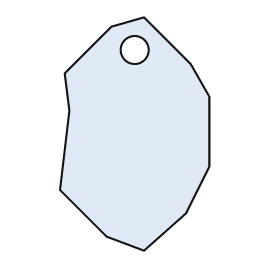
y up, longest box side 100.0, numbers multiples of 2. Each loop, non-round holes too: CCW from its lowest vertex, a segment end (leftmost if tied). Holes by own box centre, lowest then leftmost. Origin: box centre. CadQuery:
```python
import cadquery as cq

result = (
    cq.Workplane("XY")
    .moveTo(4.0, -50.0)
    .lineTo(22.0, -34.0)
    .lineTo(32.0, -14.0)
    .lineTo(32.0, 16.0)
    .lineTo(24.0, 30.0)
    .lineTo(4.0, 50.0)
    .lineTo(-10.0, 46.0)
    .lineTo(-30.0, 26.0)
    .lineTo(-28.0, 10.0)
    .lineTo(-32.0, -24.0)
    .lineTo(-12.0, -44.0)
    .close()
    .moveTo(0.0, 36.0)
    .circle(6.0)
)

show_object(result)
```